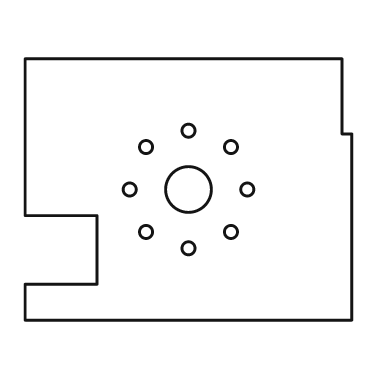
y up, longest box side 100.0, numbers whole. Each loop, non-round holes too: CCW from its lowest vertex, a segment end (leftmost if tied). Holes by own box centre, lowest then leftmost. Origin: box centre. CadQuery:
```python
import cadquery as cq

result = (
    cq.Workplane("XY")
    .moveTo(-50.0, -40.0)
    .lineTo(50.0, -40.0)
    .lineTo(50.0, 17.0)
    .lineTo(47.0, 17.0)
    .lineTo(47.0, 40.0)
    .lineTo(-50.0, 40.0)
    .lineTo(-50.0, -8.0)
    .lineTo(-28.0, -8.0)
    .lineTo(-28.0, -29.0)
    .lineTo(-50.0, -29.0)
    .close()
    .moveTo(0.0, -18.0)
    .circle(2.0)
    .moveTo(-13.0, -13.0)
    .circle(2.0)
    .moveTo(13.0, -13.0)
    .circle(2.0)
    .moveTo(-18.0, 0.0)
    .circle(2.0)
    .moveTo(0.0, 0.0)
    .circle(7.0)
    .moveTo(18.0, 0.0)
    .circle(2.0)
    .moveTo(-13.0, 13.0)
    .circle(2.0)
    .moveTo(13.0, 13.0)
    .circle(2.0)
    .moveTo(0.0, 18.0)
    .circle(2.0)
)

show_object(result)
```